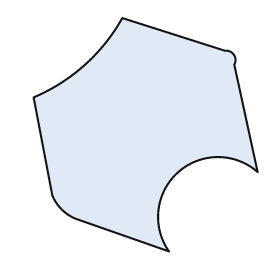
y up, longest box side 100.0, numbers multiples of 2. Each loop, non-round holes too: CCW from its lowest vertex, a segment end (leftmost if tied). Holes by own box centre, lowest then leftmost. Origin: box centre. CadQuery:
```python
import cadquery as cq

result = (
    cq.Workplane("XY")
    .moveTo(10.0, -50.0)
    .threePointArc((14.0, -16.0), (48.0, -16.0))
    .lineTo(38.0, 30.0)
    .threePointArc((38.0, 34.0), (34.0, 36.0))
    .lineTo(-10.0, 50.0)
    .threePointArc((-26.0, 30.0), (-48.0, 16.0))
    .lineTo(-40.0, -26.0)
    .threePointArc((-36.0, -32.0), (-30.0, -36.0))
    .close()
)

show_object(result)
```